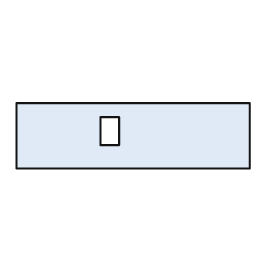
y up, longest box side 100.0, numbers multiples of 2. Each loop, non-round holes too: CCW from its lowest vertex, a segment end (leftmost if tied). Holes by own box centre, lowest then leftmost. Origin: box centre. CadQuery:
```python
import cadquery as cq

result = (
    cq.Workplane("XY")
    .moveTo(-50.0, -14.0)
    .lineTo(50.0, -14.0)
    .lineTo(50.0, 14.0)
    .lineTo(-50.0, 14.0)
    .close()
    .moveTo(-14.0, -4.0)
    .lineTo(-6.0, -4.0)
    .lineTo(-6.0, 8.0)
    .lineTo(-14.0, 8.0)
    .close()
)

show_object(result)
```